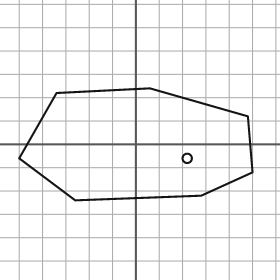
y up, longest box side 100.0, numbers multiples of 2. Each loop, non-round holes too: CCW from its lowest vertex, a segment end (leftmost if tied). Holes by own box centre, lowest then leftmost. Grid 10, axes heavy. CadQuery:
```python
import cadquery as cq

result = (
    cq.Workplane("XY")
    .moveTo(-26.0, -24.0)
    .lineTo(28.0, -22.0)
    .lineTo(50.0, -12.0)
    .lineTo(48.0, 12.0)
    .lineTo(6.0, 24.0)
    .lineTo(-34.0, 22.0)
    .lineTo(-50.0, -6.0)
    .close()
    .moveTo(22.0, -6.0)
    .circle(2.0)
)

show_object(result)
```